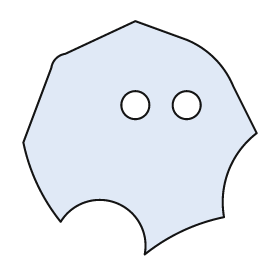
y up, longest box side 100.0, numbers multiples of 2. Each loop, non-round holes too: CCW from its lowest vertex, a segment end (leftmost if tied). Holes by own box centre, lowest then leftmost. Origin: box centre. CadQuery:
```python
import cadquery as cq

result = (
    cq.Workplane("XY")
    .moveTo(2.0, -50.0)
    .threePointArc((18.0, -40.0), (36.0, -34.0))
    .threePointArc((38.0, -14.0), (50.0, 2.0))
    .lineTo(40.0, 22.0)
    .threePointArc((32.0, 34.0), (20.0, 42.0))
    .lineTo(-2.0, 50.0)
    .lineTo(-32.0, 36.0)
    .threePointArc((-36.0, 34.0), (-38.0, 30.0))
    .lineTo(-50.0, -2.0)
    .threePointArc((-44.0, -20.0), (-34.0, -36.0))
    .threePointArc((-10.0, -28.0), (2.0, -50.0))
    .close()
    .moveTo(-2.0, 14.0)
    .circle(6.0)
    .moveTo(20.0, 14.0)
    .circle(6.0)
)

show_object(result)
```